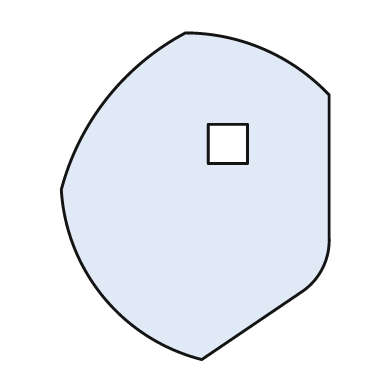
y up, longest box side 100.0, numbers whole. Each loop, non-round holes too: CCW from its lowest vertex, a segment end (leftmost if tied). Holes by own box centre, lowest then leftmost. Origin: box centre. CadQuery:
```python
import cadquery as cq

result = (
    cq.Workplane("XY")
    .moveTo(2.0, -50.0)
    .lineTo(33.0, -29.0)
    .threePointArc((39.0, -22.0), (41.0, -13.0))
    .lineTo(41.0, 31.0)
    .threePointArc((21.0, 45.0), (-3.0, 50.0))
    .threePointArc((-27.0, 30.0), (-41.0, 2.0))
    .threePointArc((-28.0, -31.0), (2.0, -50.0))
    .close()
    .moveTo(4.0, 10.0)
    .lineTo(16.0, 10.0)
    .lineTo(16.0, 22.0)
    .lineTo(4.0, 22.0)
    .close()
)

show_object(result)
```